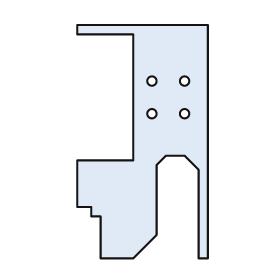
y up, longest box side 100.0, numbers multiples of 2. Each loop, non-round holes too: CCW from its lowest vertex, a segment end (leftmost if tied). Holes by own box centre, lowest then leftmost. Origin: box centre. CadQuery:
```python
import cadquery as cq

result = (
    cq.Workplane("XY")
    .moveTo(-18.0, -50.0)
    .lineTo(-4.0, -50.0)
    .lineTo(6.0, -40.0)
    .lineTo(6.0, -10.0)
    .lineTo(10.0, -6.0)
    .lineTo(18.0, -6.0)
    .lineTo(24.0, -12.0)
    .lineTo(24.0, -50.0)
    .lineTo(28.0, -50.0)
    .lineTo(28.0, 50.0)
    .lineTo(-28.0, 50.0)
    .lineTo(-28.0, 46.0)
    .lineTo(-4.0, 46.0)
    .lineTo(-4.0, -8.0)
    .lineTo(-28.0, -8.0)
    .lineTo(-28.0, -28.0)
    .lineTo(-22.0, -28.0)
    .lineTo(-22.0, -32.0)
    .lineTo(-18.0, -32.0)
    .close()
    .moveTo(4.0, 12.0)
    .circle(2.0)
    .moveTo(18.0, 12.0)
    .circle(2.0)
    .moveTo(4.0, 26.0)
    .circle(2.0)
    .moveTo(18.0, 26.0)
    .circle(2.0)
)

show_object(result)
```